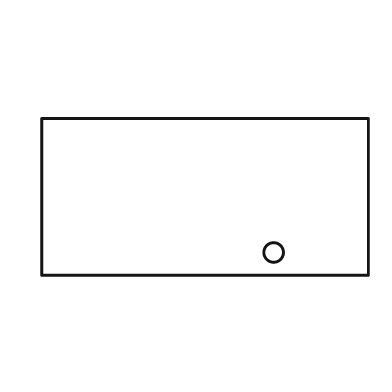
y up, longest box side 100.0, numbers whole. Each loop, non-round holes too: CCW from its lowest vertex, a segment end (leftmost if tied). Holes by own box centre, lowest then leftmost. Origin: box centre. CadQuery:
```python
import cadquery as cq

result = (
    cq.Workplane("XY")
    .moveTo(-50.0, -24.0)
    .lineTo(50.0, -24.0)
    .lineTo(50.0, 24.0)
    .lineTo(-50.0, 24.0)
    .close()
    .moveTo(21.0, -17.0)
    .circle(3.0)
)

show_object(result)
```